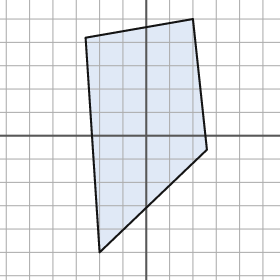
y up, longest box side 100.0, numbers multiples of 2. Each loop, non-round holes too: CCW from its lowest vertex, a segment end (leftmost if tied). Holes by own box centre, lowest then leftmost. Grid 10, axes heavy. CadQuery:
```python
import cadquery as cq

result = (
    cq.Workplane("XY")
    .moveTo(-20.0, -50.0)
    .lineTo(26.0, -6.0)
    .lineTo(20.0, 50.0)
    .lineTo(-26.0, 42.0)
    .close()
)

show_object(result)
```